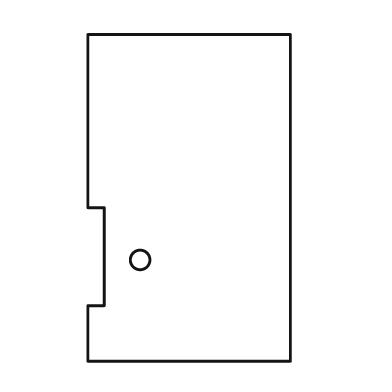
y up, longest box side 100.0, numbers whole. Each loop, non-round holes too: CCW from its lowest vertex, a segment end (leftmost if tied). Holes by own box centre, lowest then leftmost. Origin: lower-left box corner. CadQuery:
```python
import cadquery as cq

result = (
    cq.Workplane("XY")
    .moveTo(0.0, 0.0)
    .lineTo(62.0, 0.0)
    .lineTo(62.0, 100.0)
    .lineTo(0.0, 100.0)
    .lineTo(0.0, 47.0)
    .lineTo(5.0, 47.0)
    .lineTo(5.0, 17.0)
    .lineTo(0.0, 17.0)
    .close()
    .moveTo(16.0, 31.0)
    .circle(3.0)
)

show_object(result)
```